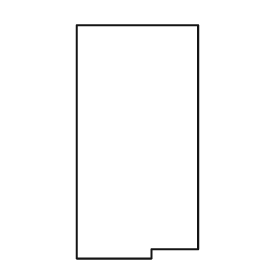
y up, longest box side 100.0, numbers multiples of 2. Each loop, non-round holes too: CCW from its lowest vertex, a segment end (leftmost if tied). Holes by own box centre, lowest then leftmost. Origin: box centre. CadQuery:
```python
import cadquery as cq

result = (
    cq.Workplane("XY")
    .moveTo(-26.0, -50.0)
    .lineTo(6.0, -50.0)
    .lineTo(6.0, -46.0)
    .lineTo(26.0, -46.0)
    .lineTo(26.0, 50.0)
    .lineTo(-26.0, 50.0)
    .close()
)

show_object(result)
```